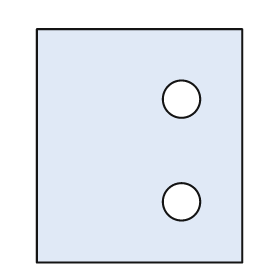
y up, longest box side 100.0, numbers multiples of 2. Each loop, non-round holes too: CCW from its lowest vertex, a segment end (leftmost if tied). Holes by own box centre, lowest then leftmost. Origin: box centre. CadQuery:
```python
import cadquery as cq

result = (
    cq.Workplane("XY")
    .moveTo(-44.0, -50.0)
    .lineTo(44.0, -50.0)
    .lineTo(44.0, 50.0)
    .lineTo(-44.0, 50.0)
    .close()
    .moveTo(18.0, -24.0)
    .circle(8.0)
    .moveTo(18.0, 20.0)
    .circle(8.0)
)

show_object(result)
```